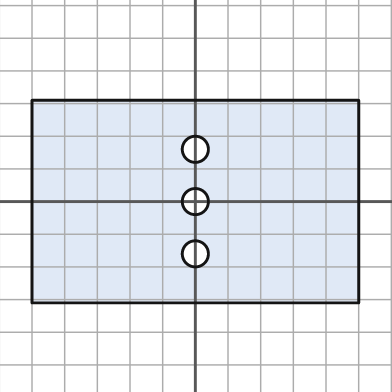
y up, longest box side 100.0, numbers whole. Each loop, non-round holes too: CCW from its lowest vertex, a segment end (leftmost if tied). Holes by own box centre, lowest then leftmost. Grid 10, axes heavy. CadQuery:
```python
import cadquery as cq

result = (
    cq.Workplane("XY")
    .moveTo(-50.0, -31.0)
    .lineTo(50.0, -31.0)
    .lineTo(50.0, 31.0)
    .lineTo(-50.0, 31.0)
    .close()
    .moveTo(0.0, -16.0)
    .circle(4.0)
    .moveTo(0.0, 0.0)
    .circle(4.0)
    .moveTo(0.0, 16.0)
    .circle(4.0)
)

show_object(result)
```